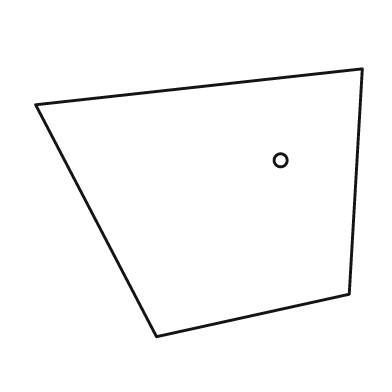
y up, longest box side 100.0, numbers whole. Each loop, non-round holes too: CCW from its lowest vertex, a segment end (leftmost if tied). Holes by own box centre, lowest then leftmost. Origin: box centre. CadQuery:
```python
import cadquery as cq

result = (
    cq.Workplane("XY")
    .moveTo(-13.0, -41.0)
    .lineTo(46.0, -28.0)
    .lineTo(50.0, 41.0)
    .lineTo(-50.0, 30.0)
    .close()
    .moveTo(25.0, 13.0)
    .circle(2.0)
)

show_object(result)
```